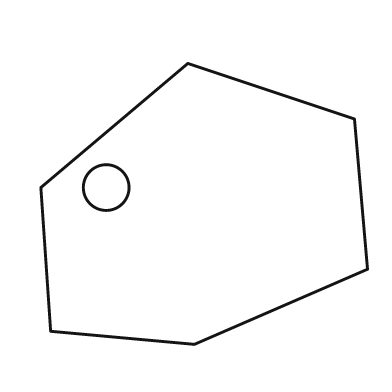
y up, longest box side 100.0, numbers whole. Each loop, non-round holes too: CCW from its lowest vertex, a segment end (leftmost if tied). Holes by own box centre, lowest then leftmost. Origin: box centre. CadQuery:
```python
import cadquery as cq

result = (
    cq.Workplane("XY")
    .moveTo(-3.0, -43.0)
    .lineTo(50.0, -20.0)
    .lineTo(46.0, 26.0)
    .lineTo(-5.0, 43.0)
    .lineTo(-50.0, 5.0)
    .lineTo(-47.0, -39.0)
    .close()
    .moveTo(-30.0, 5.0)
    .circle(7.0)
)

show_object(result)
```